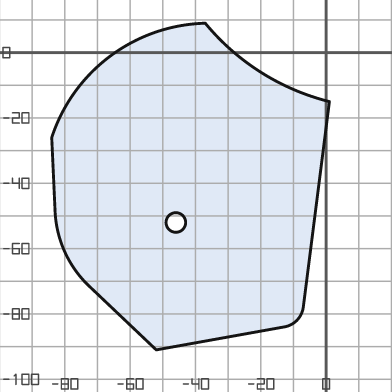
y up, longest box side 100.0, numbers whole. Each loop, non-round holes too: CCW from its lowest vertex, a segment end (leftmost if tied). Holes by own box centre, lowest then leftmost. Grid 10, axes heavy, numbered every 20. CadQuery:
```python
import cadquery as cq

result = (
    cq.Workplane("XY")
    .moveTo(-52.0, -91.0)
    .lineTo(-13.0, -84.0)
    .threePointArc((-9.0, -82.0), (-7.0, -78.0))
    .lineTo(1.0, -15.0)
    .threePointArc((-20.0, -6.0), (-37.0, 9.0))
    .threePointArc((-66.0, -1.0), (-84.0, -26.0))
    .lineTo(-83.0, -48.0)
    .threePointArc((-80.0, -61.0), (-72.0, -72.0))
    .close()
    .moveTo(-46.0, -52.0)
    .circle(3.0)
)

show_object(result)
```